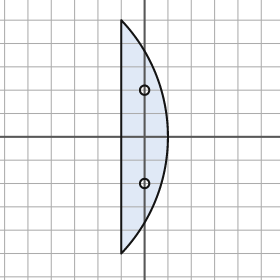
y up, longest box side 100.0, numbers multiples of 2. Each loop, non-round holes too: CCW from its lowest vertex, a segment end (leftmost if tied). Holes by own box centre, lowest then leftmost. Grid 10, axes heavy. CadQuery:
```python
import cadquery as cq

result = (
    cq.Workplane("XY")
    .moveTo(-10.0, -50.0)
    .threePointArc((10.0, 0.0), (-10.0, 50.0))
    .close()
    .moveTo(0.0, -20.0)
    .circle(2.0)
    .moveTo(0.0, 20.0)
    .circle(2.0)
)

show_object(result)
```